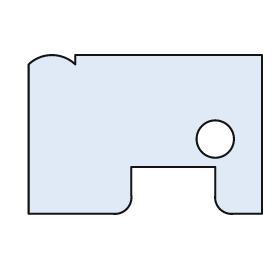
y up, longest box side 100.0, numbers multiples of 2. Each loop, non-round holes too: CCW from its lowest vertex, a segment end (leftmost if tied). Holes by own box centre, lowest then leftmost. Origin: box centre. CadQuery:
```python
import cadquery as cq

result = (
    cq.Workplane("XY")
    .moveTo(-50.0, -34.0)
    .lineTo(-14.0, -34.0)
    .threePointArc((-8.0, -32.0), (-6.0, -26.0))
    .lineTo(-6.0, -14.0)
    .lineTo(30.0, -14.0)
    .lineTo(30.0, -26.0)
    .threePointArc((32.0, -32.0), (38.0, -34.0))
    .lineTo(50.0, -34.0)
    .lineTo(50.0, 34.0)
    .lineTo(-30.0, 34.0)
    .lineTo(-30.0, 30.0)
    .threePointArc((-40.0, 34.0), (-50.0, 30.0))
    .close()
    .moveTo(30.0, -2.0)
    .circle(8.0)
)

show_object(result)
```